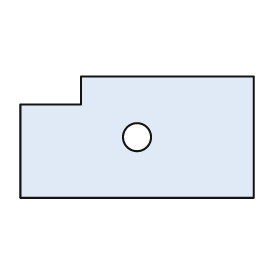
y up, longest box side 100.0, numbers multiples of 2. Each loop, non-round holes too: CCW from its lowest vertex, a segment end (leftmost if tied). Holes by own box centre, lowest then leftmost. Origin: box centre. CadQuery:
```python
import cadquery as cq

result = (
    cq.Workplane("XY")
    .moveTo(-50.0, -26.0)
    .lineTo(50.0, -26.0)
    .lineTo(50.0, 26.0)
    .lineTo(-24.0, 26.0)
    .lineTo(-24.0, 14.0)
    .lineTo(-50.0, 14.0)
    .close()
    .moveTo(0.0, 0.0)
    .circle(6.0)
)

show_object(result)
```